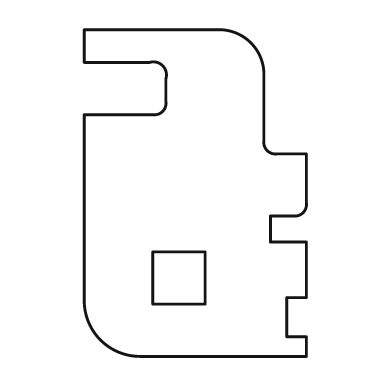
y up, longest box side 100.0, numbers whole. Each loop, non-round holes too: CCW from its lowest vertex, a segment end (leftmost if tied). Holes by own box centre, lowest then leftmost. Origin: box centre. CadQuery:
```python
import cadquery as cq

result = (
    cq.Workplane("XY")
    .moveTo(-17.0, -50.0)
    .lineTo(34.0, -50.0)
    .lineTo(34.0, -44.0)
    .lineTo(28.0, -44.0)
    .lineTo(28.0, -32.0)
    .lineTo(34.0, -32.0)
    .lineTo(34.0, -15.0)
    .lineTo(23.0, -15.0)
    .lineTo(23.0, -7.0)
    .lineTo(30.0, -7.0)
    .threePointArc((33.0, -6.0), (34.0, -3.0))
    .lineTo(34.0, 12.0)
    .lineTo(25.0, 12.0)
    .threePointArc((22.0, 13.0), (21.0, 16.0))
    .lineTo(21.0, 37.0)
    .threePointArc((17.0, 46.0), (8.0, 50.0))
    .lineTo(-34.0, 50.0)
    .lineTo(-34.0, 40.0)
    .lineTo(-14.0, 40.0)
    .threePointArc((-10.0, 39.0), (-9.0, 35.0))
    .lineTo(-9.0, 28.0)
    .threePointArc((-10.0, 25.0), (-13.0, 24.0))
    .lineTo(-34.0, 24.0)
    .lineTo(-34.0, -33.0)
    .threePointArc((-29.0, -45.0), (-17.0, -50.0))
    .close()
    .moveTo(-13.0, -34.0)
    .lineTo(3.0, -34.0)
    .lineTo(3.0, -18.0)
    .lineTo(-13.0, -18.0)
    .close()
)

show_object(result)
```